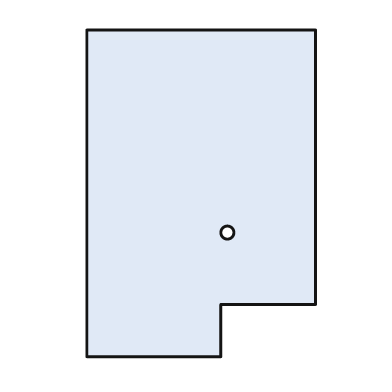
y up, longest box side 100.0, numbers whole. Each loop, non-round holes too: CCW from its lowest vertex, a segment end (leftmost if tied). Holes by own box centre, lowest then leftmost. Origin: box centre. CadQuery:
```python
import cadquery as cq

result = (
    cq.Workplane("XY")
    .moveTo(-35.0, -50.0)
    .lineTo(6.0, -50.0)
    .lineTo(6.0, -34.0)
    .lineTo(35.0, -34.0)
    .lineTo(35.0, 50.0)
    .lineTo(-35.0, 50.0)
    .close()
    .moveTo(8.0, -12.0)
    .circle(2.0)
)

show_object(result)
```